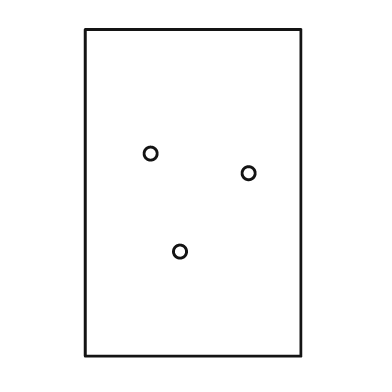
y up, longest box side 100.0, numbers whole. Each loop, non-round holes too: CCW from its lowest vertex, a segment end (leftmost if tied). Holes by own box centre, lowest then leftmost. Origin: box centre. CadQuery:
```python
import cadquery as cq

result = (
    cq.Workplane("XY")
    .moveTo(-33.0, -50.0)
    .lineTo(33.0, -50.0)
    .lineTo(33.0, 50.0)
    .lineTo(-33.0, 50.0)
    .close()
    .moveTo(-4.0, -18.0)
    .circle(2.0)
    .moveTo(17.0, 6.0)
    .circle(2.0)
    .moveTo(-13.0, 12.0)
    .circle(2.0)
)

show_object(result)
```